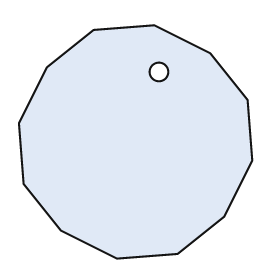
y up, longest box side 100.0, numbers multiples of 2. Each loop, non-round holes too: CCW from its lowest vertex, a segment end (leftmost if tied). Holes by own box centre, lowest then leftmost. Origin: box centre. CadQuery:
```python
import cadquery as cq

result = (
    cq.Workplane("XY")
    .moveTo(-8.0, -50.0)
    .lineTo(18.0, -48.0)
    .lineTo(38.0, -32.0)
    .lineTo(50.0, -8.0)
    .lineTo(48.0, 18.0)
    .lineTo(32.0, 38.0)
    .lineTo(8.0, 50.0)
    .lineTo(-18.0, 48.0)
    .lineTo(-38.0, 32.0)
    .lineTo(-50.0, 8.0)
    .lineTo(-48.0, -18.0)
    .lineTo(-32.0, -38.0)
    .close()
    .moveTo(10.0, 30.0)
    .circle(4.0)
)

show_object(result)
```